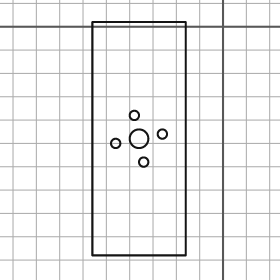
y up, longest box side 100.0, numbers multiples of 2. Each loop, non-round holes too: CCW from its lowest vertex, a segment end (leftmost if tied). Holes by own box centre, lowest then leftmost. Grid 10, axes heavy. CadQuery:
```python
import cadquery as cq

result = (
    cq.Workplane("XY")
    .moveTo(-56.0, -98.0)
    .lineTo(-16.0, -98.0)
    .lineTo(-16.0, 2.0)
    .lineTo(-56.0, 2.0)
    .close()
    .moveTo(-34.0, -58.0)
    .circle(2.0)
    .moveTo(-46.0, -50.0)
    .circle(2.0)
    .moveTo(-36.0, -48.0)
    .circle(4.0)
    .moveTo(-26.0, -46.0)
    .circle(2.0)
    .moveTo(-38.0, -38.0)
    .circle(2.0)
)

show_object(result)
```